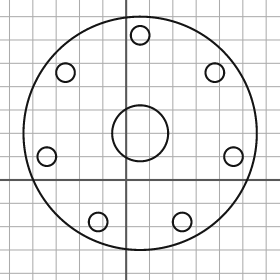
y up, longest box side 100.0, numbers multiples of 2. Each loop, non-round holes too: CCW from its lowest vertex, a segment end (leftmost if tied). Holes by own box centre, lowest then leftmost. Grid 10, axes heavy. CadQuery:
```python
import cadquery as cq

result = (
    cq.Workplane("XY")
    .moveTo(6.0, 20.0)
    .circle(50.0)
    .moveTo(-12.0, -18.0)
    .circle(4.0)
    .moveTo(24.0, -18.0)
    .circle(4.0)
    .moveTo(-34.0, 10.0)
    .circle(4.0)
    .moveTo(46.0, 10.0)
    .circle(4.0)
    .moveTo(6.0, 20.0)
    .circle(12.0)
    .moveTo(-26.0, 46.0)
    .circle(4.0)
    .moveTo(38.0, 46.0)
    .circle(4.0)
    .moveTo(6.0, 62.0)
    .circle(4.0)
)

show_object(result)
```